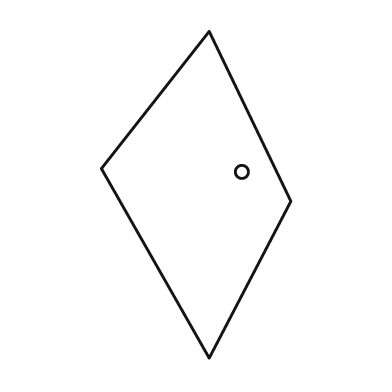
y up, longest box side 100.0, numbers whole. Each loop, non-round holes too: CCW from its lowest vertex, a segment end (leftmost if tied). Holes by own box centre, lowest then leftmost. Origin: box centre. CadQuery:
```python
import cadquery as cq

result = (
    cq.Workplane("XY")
    .moveTo(4.0, -50.0)
    .lineTo(29.0, -2.0)
    .lineTo(4.0, 50.0)
    .lineTo(-29.0, 8.0)
    .close()
    .moveTo(14.0, 7.0)
    .circle(2.0)
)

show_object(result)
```